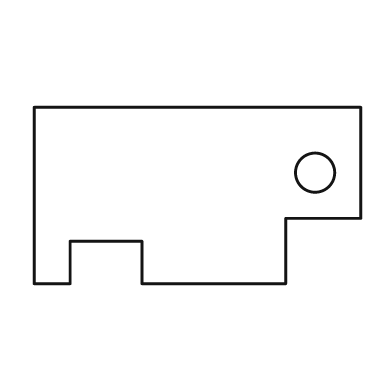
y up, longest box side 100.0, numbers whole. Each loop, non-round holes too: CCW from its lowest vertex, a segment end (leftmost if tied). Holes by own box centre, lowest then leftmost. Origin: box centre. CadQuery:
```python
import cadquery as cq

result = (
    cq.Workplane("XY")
    .moveTo(-50.0, -27.0)
    .lineTo(-39.0, -27.0)
    .lineTo(-39.0, -14.0)
    .lineTo(-17.0, -14.0)
    .lineTo(-17.0, -27.0)
    .lineTo(27.0, -27.0)
    .lineTo(27.0, -7.0)
    .lineTo(50.0, -7.0)
    .lineTo(50.0, 27.0)
    .lineTo(-50.0, 27.0)
    .close()
    .moveTo(36.0, 7.0)
    .circle(6.0)
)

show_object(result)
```